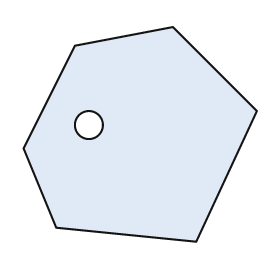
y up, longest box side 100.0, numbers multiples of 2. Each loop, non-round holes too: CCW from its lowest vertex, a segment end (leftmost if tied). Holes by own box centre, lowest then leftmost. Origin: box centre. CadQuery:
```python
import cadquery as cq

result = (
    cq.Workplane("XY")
    .moveTo(24.0, -46.0)
    .lineTo(50.0, 10.0)
    .lineTo(14.0, 46.0)
    .lineTo(-28.0, 38.0)
    .lineTo(-50.0, -6.0)
    .lineTo(-36.0, -40.0)
    .close()
    .moveTo(-22.0, 4.0)
    .circle(6.0)
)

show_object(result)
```